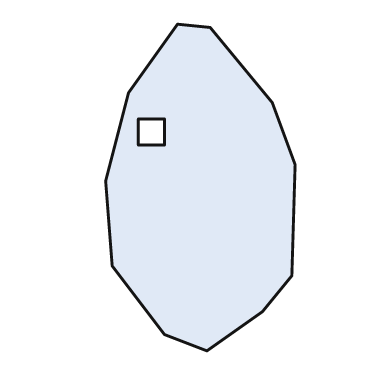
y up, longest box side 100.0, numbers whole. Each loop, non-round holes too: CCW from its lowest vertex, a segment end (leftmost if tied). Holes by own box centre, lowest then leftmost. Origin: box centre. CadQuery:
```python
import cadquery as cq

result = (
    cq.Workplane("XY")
    .moveTo(2.0, -50.0)
    .lineTo(19.0, -38.0)
    .lineTo(28.0, -27.0)
    .lineTo(29.0, 7.0)
    .lineTo(22.0, 26.0)
    .lineTo(3.0, 49.0)
    .lineTo(-7.0, 50.0)
    .lineTo(-22.0, 29.0)
    .lineTo(-29.0, 2.0)
    .lineTo(-27.0, -24.0)
    .lineTo(-11.0, -45.0)
    .close()
    .moveTo(-19.0, 13.0)
    .lineTo(-11.0, 13.0)
    .lineTo(-11.0, 21.0)
    .lineTo(-19.0, 21.0)
    .close()
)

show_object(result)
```